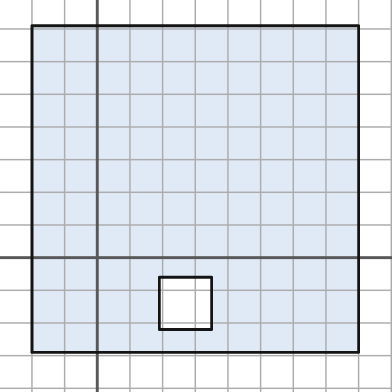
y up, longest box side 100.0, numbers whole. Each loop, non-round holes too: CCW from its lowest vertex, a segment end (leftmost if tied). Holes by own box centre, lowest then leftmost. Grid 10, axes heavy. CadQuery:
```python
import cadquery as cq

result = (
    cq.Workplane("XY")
    .moveTo(-20.0, -29.0)
    .lineTo(80.0, -29.0)
    .lineTo(80.0, 71.0)
    .lineTo(-20.0, 71.0)
    .close()
    .moveTo(19.0, -22.0)
    .lineTo(35.0, -22.0)
    .lineTo(35.0, -6.0)
    .lineTo(19.0, -6.0)
    .close()
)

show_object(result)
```